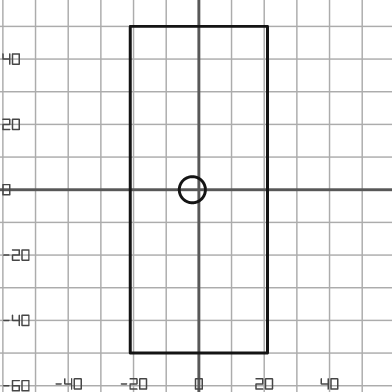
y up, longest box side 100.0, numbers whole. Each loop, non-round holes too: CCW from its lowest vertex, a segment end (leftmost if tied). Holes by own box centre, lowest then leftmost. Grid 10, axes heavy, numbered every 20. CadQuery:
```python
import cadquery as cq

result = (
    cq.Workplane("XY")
    .moveTo(-21.0, -50.0)
    .lineTo(21.0, -50.0)
    .lineTo(21.0, 50.0)
    .lineTo(-21.0, 50.0)
    .close()
    .moveTo(-2.0, 0.0)
    .circle(4.0)
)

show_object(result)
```